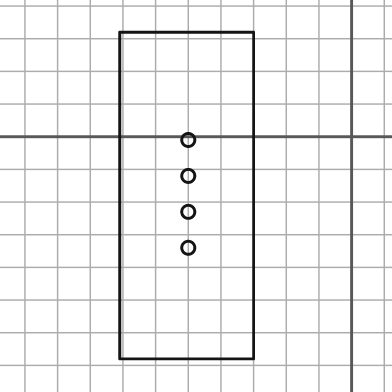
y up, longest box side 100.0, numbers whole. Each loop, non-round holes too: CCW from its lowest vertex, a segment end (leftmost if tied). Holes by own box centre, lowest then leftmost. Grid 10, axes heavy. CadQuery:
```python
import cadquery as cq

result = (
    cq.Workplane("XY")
    .moveTo(-71.0, -68.0)
    .lineTo(-30.0, -68.0)
    .lineTo(-30.0, 32.0)
    .lineTo(-71.0, 32.0)
    .close()
    .moveTo(-50.0, -34.0)
    .circle(2.0)
    .moveTo(-50.0, -23.0)
    .circle(2.0)
    .moveTo(-50.0, -12.0)
    .circle(2.0)
    .moveTo(-50.0, -1.0)
    .circle(2.0)
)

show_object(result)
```